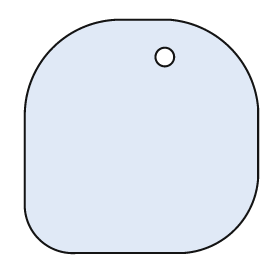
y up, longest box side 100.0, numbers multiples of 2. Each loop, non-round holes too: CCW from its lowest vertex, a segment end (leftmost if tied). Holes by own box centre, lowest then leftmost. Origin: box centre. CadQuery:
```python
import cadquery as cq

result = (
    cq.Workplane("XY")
    .moveTo(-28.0, -50.0)
    .lineTo(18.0, -50.0)
    .threePointArc((40.0, -40.0), (50.0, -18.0))
    .lineTo(50.0, 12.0)
    .threePointArc((38.0, 38.0), (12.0, 50.0))
    .lineTo(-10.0, 50.0)
    .threePointArc((-38.0, 38.0), (-50.0, 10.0))
    .lineTo(-50.0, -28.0)
    .threePointArc((-44.0, -44.0), (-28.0, -50.0))
    .close()
    .moveTo(10.0, 34.0)
    .circle(4.0)
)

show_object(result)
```